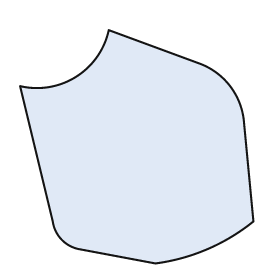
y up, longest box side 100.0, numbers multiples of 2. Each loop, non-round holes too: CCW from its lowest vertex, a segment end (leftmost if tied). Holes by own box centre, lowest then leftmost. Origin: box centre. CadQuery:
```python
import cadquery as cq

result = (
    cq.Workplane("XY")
    .moveTo(8.0, -50.0)
    .threePointArc((30.0, -44.0), (50.0, -32.0))
    .lineTo(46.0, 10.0)
    .threePointArc((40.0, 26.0), (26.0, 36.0))
    .lineTo(-12.0, 50.0)
    .threePointArc((-26.0, 30.0), (-50.0, 26.0))
    .lineTo(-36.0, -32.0)
    .threePointArc((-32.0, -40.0), (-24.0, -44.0))
    .close()
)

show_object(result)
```